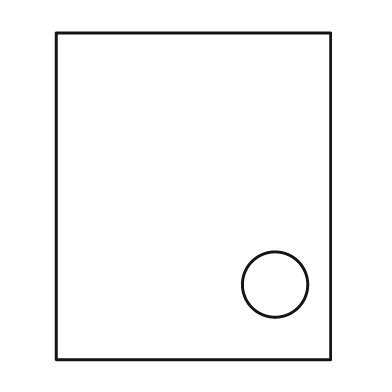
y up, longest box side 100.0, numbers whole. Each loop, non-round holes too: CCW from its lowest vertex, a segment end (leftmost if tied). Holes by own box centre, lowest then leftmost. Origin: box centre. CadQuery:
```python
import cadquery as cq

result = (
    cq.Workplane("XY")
    .moveTo(-42.0, -50.0)
    .lineTo(42.0, -50.0)
    .lineTo(42.0, 50.0)
    .lineTo(-42.0, 50.0)
    .close()
    .moveTo(25.0, -27.0)
    .circle(10.0)
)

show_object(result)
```